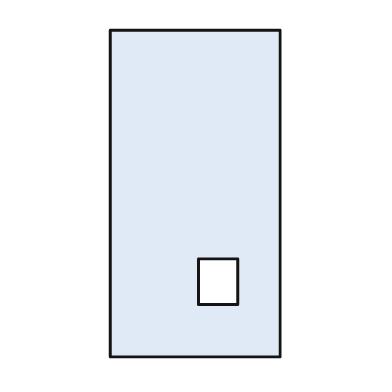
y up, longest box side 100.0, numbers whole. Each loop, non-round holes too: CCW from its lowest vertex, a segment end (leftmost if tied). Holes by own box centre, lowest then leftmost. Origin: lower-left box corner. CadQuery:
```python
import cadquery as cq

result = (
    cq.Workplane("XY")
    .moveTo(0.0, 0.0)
    .lineTo(52.0, 0.0)
    .lineTo(52.0, 100.0)
    .lineTo(0.0, 100.0)
    .close()
    .moveTo(27.0, 16.0)
    .lineTo(39.0, 16.0)
    .lineTo(39.0, 30.0)
    .lineTo(27.0, 30.0)
    .close()
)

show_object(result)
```